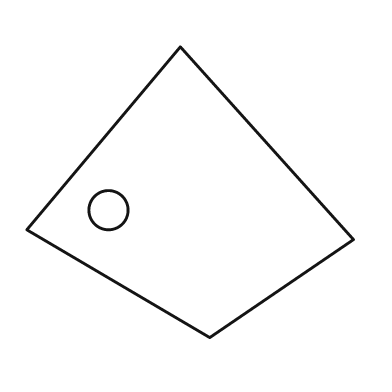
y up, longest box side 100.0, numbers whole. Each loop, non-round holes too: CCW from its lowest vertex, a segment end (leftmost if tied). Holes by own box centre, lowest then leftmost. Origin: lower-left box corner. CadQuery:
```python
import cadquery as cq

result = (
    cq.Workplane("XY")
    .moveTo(56.0, 0.0)
    .lineTo(100.0, 30.0)
    .lineTo(47.0, 89.0)
    .lineTo(0.0, 33.0)
    .close()
    .moveTo(25.0, 39.0)
    .circle(6.0)
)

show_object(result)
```